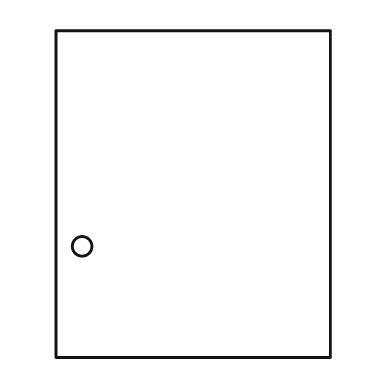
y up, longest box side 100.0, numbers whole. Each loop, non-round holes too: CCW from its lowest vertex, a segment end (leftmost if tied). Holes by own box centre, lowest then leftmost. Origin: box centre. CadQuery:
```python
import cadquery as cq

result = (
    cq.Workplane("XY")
    .moveTo(-42.0, -50.0)
    .lineTo(42.0, -50.0)
    .lineTo(42.0, 50.0)
    .lineTo(-42.0, 50.0)
    .close()
    .moveTo(-34.0, -16.0)
    .circle(3.0)
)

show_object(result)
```